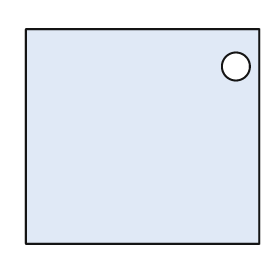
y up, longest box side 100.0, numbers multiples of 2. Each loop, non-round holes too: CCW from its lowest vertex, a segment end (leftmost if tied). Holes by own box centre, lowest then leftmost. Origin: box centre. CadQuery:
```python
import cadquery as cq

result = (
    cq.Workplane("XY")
    .moveTo(-50.0, -46.0)
    .lineTo(50.0, -46.0)
    .lineTo(50.0, 46.0)
    .lineTo(-50.0, 46.0)
    .close()
    .moveTo(40.0, 30.0)
    .circle(6.0)
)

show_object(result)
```